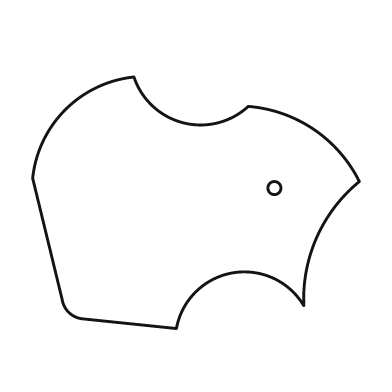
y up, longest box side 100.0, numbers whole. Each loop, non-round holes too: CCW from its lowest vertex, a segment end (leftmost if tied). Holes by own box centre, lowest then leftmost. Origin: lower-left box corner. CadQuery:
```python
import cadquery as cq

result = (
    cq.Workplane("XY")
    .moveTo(44.0, 0.0)
    .threePointArc((61.0, 17.0), (83.0, 7.0))
    .threePointArc((87.0, 28.0), (100.0, 45.0))
    .threePointArc((86.0, 61.0), (66.0, 68.0))
    .threePointArc((46.0, 63.0), (31.0, 77.0))
    .threePointArc((10.0, 67.0), (0.0, 46.0))
    .lineTo(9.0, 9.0)
    .threePointArc((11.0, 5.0), (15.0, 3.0))
    .close()
    .moveTo(74.0, 43.0)
    .circle(2.0)
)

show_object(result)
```